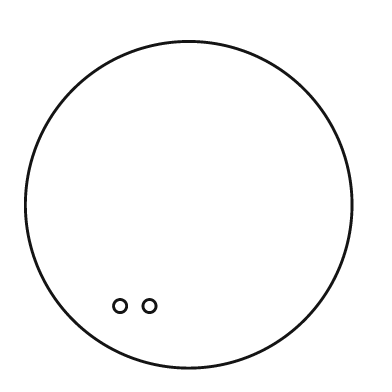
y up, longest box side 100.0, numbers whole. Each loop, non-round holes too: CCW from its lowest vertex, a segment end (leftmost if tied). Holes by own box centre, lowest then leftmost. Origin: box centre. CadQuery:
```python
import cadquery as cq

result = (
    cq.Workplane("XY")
    .moveTo(0.0, 0.0)
    .circle(50.0)
    .moveTo(-21.0, -31.0)
    .circle(2.0)
    .moveTo(-12.0, -31.0)
    .circle(2.0)
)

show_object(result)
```